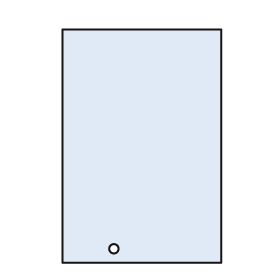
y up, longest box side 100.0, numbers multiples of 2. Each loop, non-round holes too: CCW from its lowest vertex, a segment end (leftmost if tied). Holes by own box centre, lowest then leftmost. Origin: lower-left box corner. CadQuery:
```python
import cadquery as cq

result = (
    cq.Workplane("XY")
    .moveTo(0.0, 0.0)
    .lineTo(68.0, 0.0)
    .lineTo(68.0, 100.0)
    .lineTo(0.0, 100.0)
    .close()
    .moveTo(22.0, 6.0)
    .circle(2.0)
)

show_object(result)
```